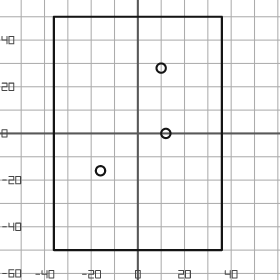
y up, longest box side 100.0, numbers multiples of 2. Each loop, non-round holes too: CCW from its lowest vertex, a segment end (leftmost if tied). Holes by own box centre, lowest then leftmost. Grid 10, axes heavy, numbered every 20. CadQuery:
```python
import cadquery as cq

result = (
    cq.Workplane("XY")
    .moveTo(-36.0, -50.0)
    .lineTo(36.0, -50.0)
    .lineTo(36.0, 50.0)
    .lineTo(-36.0, 50.0)
    .close()
    .moveTo(-16.0, -16.0)
    .circle(2.0)
    .moveTo(12.0, 0.0)
    .circle(2.0)
    .moveTo(10.0, 28.0)
    .circle(2.0)
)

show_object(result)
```